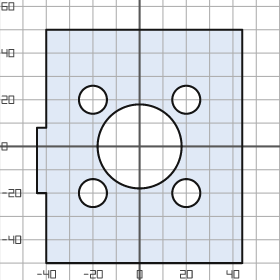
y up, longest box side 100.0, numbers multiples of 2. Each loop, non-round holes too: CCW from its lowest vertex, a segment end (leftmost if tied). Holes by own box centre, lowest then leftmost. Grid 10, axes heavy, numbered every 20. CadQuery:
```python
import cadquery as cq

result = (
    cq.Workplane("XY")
    .moveTo(-40.0, -50.0)
    .lineTo(44.0, -50.0)
    .lineTo(44.0, 50.0)
    .lineTo(-40.0, 50.0)
    .lineTo(-40.0, 8.0)
    .lineTo(-44.0, 8.0)
    .lineTo(-44.0, -20.0)
    .lineTo(-40.0, -20.0)
    .close()
    .moveTo(-20.0, -20.0)
    .circle(6.0)
    .moveTo(20.0, -20.0)
    .circle(6.0)
    .moveTo(0.0, 0.0)
    .circle(18.0)
    .moveTo(-20.0, 20.0)
    .circle(6.0)
    .moveTo(20.0, 20.0)
    .circle(6.0)
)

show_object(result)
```